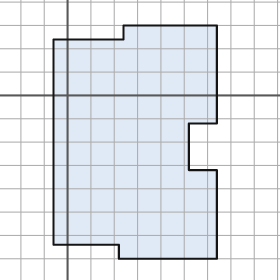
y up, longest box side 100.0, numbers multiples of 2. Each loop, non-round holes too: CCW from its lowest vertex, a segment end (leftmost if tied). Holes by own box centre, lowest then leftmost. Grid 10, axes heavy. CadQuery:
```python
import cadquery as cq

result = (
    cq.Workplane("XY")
    .moveTo(22.0, -70.0)
    .lineTo(64.0, -70.0)
    .lineTo(64.0, -32.0)
    .lineTo(52.0, -32.0)
    .lineTo(52.0, -12.0)
    .lineTo(64.0, -12.0)
    .lineTo(64.0, 30.0)
    .lineTo(24.0, 30.0)
    .lineTo(24.0, 24.0)
    .lineTo(-6.0, 24.0)
    .lineTo(-6.0, -64.0)
    .lineTo(22.0, -64.0)
    .close()
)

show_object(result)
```